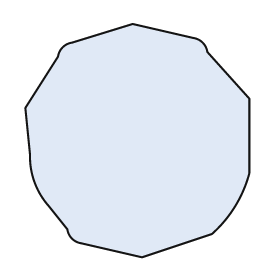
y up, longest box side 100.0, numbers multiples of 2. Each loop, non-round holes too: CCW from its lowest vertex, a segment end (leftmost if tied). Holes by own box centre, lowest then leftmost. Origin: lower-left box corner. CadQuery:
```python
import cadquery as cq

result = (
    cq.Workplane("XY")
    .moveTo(50.0, 0.0)
    .lineTo(80.0, 10.0)
    .threePointArc((90.0, 22.0), (96.0, 36.0))
    .lineTo(96.0, 68.0)
    .lineTo(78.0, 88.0)
    .threePointArc((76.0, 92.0), (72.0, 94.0))
    .lineTo(46.0, 100.0)
    .lineTo(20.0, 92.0)
    .threePointArc((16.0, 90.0), (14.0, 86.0))
    .lineTo(0.0, 64.0)
    .lineTo(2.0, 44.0)
    .threePointArc((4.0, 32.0), (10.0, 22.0))
    .lineTo(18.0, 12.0)
    .threePointArc((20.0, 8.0), (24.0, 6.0))
    .close()
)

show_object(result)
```